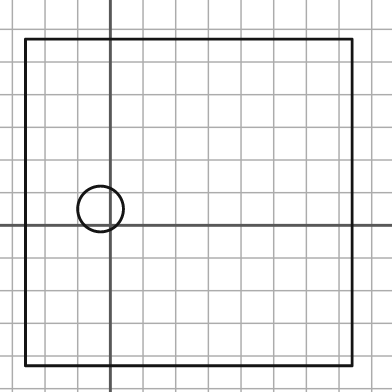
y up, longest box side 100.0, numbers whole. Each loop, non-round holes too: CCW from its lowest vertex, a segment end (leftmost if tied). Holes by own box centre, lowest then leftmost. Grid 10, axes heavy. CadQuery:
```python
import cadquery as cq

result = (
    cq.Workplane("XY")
    .moveTo(-26.0, -43.0)
    .lineTo(74.0, -43.0)
    .lineTo(74.0, 57.0)
    .lineTo(-26.0, 57.0)
    .close()
    .moveTo(-3.0, 5.0)
    .circle(7.0)
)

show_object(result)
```